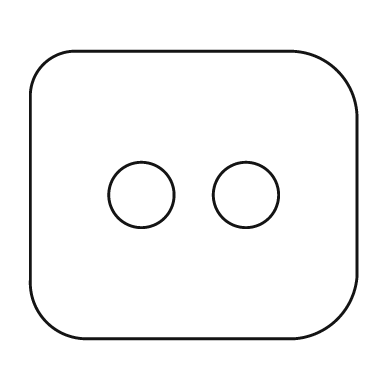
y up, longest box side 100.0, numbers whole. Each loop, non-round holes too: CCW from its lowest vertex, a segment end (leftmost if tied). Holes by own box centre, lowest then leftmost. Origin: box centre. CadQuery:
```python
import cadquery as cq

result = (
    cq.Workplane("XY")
    .moveTo(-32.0, -44.0)
    .lineTo(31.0, -44.0)
    .threePointArc((44.0, -38.0), (50.0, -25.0))
    .lineTo(50.0, 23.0)
    .threePointArc((44.0, 38.0), (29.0, 44.0))
    .lineTo(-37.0, 44.0)
    .threePointArc((-46.0, 40.0), (-50.0, 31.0))
    .lineTo(-50.0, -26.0)
    .threePointArc((-45.0, -39.0), (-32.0, -44.0))
    .close()
    .moveTo(-16.0, 0.0)
    .circle(10.0)
    .moveTo(16.0, 0.0)
    .circle(10.0)
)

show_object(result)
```